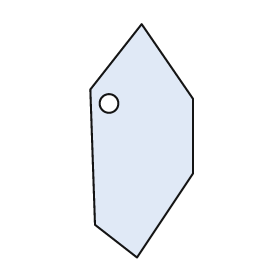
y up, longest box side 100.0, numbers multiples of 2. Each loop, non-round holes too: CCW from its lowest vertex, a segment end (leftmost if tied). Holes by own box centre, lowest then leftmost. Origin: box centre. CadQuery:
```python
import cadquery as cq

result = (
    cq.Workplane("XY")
    .moveTo(-2.0, -50.0)
    .lineTo(22.0, -14.0)
    .lineTo(22.0, 18.0)
    .lineTo(0.0, 50.0)
    .lineTo(-22.0, 22.0)
    .lineTo(-20.0, -36.0)
    .close()
    .moveTo(-14.0, 16.0)
    .circle(4.0)
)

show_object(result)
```